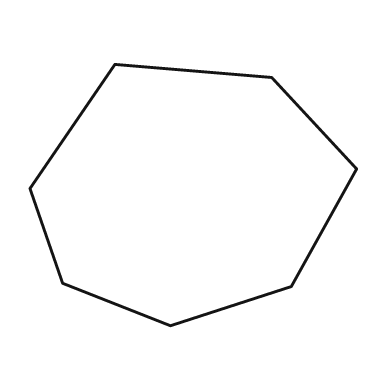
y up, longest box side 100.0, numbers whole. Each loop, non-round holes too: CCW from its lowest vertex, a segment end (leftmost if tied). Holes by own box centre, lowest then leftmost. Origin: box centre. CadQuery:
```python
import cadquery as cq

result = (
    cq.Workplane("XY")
    .moveTo(-7.0, -40.0)
    .lineTo(30.0, -28.0)
    .lineTo(50.0, 8.0)
    .lineTo(24.0, 36.0)
    .lineTo(-24.0, 40.0)
    .lineTo(-50.0, 2.0)
    .lineTo(-40.0, -27.0)
    .close()
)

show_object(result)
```